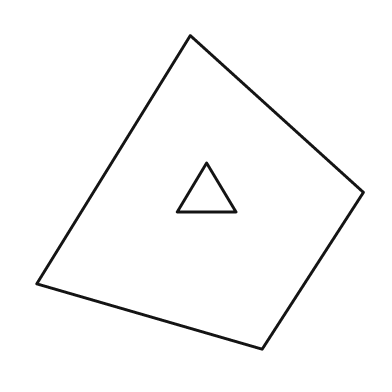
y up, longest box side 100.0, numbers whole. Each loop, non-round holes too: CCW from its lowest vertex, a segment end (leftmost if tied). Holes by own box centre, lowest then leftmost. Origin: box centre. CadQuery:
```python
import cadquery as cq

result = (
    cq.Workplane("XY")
    .moveTo(19.0, -48.0)
    .lineTo(50.0, 0.0)
    .lineTo(-3.0, 48.0)
    .lineTo(-50.0, -28.0)
    .close()
    .moveTo(-7.0, -6.0)
    .lineTo(11.0, -6.0)
    .lineTo(2.0, 9.0)
    .close()
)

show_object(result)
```